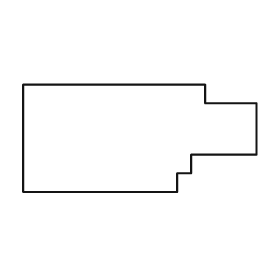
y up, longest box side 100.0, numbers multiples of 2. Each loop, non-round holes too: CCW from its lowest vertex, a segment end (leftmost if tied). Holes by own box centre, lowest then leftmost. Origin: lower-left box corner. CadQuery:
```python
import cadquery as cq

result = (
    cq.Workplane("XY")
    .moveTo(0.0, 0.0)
    .lineTo(66.0, 0.0)
    .lineTo(66.0, 8.0)
    .lineTo(72.0, 8.0)
    .lineTo(72.0, 16.0)
    .lineTo(100.0, 16.0)
    .lineTo(100.0, 38.0)
    .lineTo(78.0, 38.0)
    .lineTo(78.0, 46.0)
    .lineTo(0.0, 46.0)
    .close()
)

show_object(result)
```